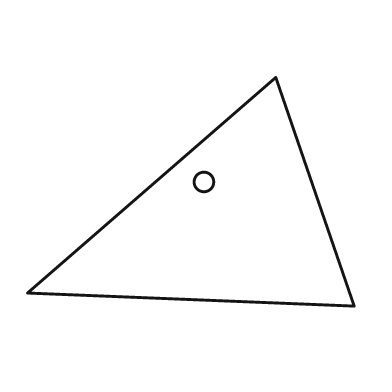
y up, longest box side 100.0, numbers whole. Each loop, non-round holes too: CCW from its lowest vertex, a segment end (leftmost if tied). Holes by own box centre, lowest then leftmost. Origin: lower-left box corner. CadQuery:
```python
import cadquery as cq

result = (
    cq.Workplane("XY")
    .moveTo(100.0, 0.0)
    .lineTo(76.0, 70.0)
    .lineTo(0.0, 4.0)
    .close()
    .moveTo(54.0, 38.0)
    .circle(3.0)
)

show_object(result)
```